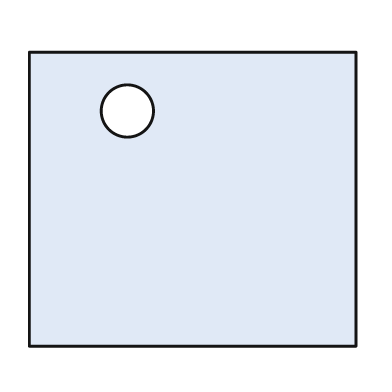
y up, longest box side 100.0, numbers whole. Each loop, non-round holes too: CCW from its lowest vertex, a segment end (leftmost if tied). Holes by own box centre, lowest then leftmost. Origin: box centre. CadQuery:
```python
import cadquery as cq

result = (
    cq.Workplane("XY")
    .moveTo(-50.0, -45.0)
    .lineTo(50.0, -45.0)
    .lineTo(50.0, 45.0)
    .lineTo(-50.0, 45.0)
    .close()
    .moveTo(-20.0, 27.0)
    .circle(8.0)
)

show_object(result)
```